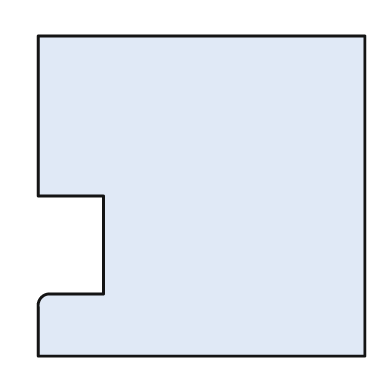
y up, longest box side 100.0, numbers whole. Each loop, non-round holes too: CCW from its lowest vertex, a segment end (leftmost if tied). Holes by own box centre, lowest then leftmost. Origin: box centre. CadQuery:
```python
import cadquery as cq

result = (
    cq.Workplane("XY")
    .moveTo(-50.0, -49.0)
    .lineTo(50.0, -49.0)
    .lineTo(50.0, 49.0)
    .lineTo(-50.0, 49.0)
    .lineTo(-50.0, 0.0)
    .lineTo(-30.0, 0.0)
    .lineTo(-30.0, -30.0)
    .lineTo(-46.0, -30.0)
    .threePointArc((-49.0, -31.0), (-50.0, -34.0))
    .close()
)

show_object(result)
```